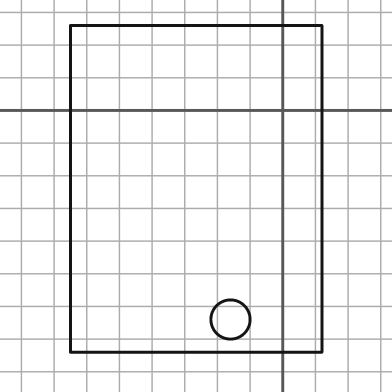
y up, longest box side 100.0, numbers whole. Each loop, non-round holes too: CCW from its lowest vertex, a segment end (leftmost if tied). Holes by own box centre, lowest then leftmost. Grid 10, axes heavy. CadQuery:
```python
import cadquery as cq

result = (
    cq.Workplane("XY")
    .moveTo(-65.0, -74.0)
    .lineTo(12.0, -74.0)
    .lineTo(12.0, 26.0)
    .lineTo(-65.0, 26.0)
    .close()
    .moveTo(-16.0, -64.0)
    .circle(6.0)
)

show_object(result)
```